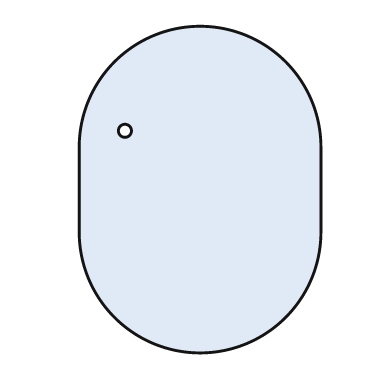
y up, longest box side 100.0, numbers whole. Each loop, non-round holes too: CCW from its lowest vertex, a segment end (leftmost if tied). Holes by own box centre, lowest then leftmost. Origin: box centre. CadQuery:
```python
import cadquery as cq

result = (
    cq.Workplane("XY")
    .moveTo(-37.0, -13.0)
    .threePointArc((0.0, -50.0), (37.0, -13.0))
    .lineTo(37.0, 13.0)
    .threePointArc((0.0, 50.0), (-37.0, 13.0))
    .close()
    .moveTo(-23.0, 18.0)
    .circle(2.0)
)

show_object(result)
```